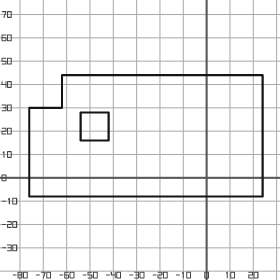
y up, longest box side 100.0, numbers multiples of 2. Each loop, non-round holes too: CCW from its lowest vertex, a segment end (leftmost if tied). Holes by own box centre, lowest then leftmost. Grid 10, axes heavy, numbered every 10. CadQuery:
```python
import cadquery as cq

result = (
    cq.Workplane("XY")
    .moveTo(-76.0, -8.0)
    .lineTo(24.0, -8.0)
    .lineTo(24.0, 44.0)
    .lineTo(-62.0, 44.0)
    .lineTo(-62.0, 30.0)
    .lineTo(-76.0, 30.0)
    .close()
    .moveTo(-54.0, 16.0)
    .lineTo(-42.0, 16.0)
    .lineTo(-42.0, 28.0)
    .lineTo(-54.0, 28.0)
    .close()
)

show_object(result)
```